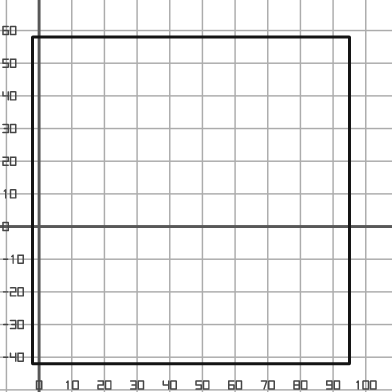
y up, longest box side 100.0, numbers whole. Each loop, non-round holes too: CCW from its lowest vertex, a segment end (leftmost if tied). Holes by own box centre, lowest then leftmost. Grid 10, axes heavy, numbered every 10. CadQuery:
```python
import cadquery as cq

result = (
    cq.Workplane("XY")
    .moveTo(-2.0, -42.0)
    .lineTo(95.0, -42.0)
    .lineTo(95.0, 58.0)
    .lineTo(-2.0, 58.0)
    .close()
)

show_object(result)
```